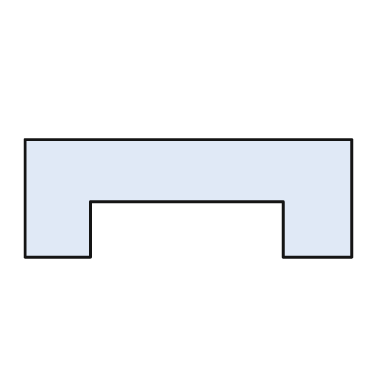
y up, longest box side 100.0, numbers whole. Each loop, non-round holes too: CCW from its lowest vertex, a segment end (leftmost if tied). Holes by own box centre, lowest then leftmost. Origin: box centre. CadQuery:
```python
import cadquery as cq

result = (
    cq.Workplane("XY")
    .moveTo(-50.0, -18.0)
    .lineTo(-30.0, -18.0)
    .lineTo(-30.0, -1.0)
    .lineTo(29.0, -1.0)
    .lineTo(29.0, -18.0)
    .lineTo(50.0, -18.0)
    .lineTo(50.0, 18.0)
    .lineTo(-50.0, 18.0)
    .close()
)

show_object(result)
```